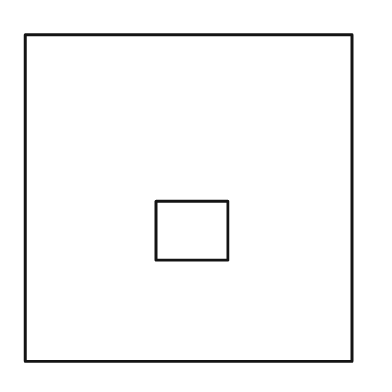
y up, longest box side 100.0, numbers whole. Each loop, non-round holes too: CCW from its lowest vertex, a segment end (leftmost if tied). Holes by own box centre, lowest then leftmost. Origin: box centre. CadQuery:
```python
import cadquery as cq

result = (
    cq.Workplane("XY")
    .moveTo(-50.0, -50.0)
    .lineTo(50.0, -50.0)
    .lineTo(50.0, 50.0)
    .lineTo(-50.0, 50.0)
    .close()
    .moveTo(-10.0, -19.0)
    .lineTo(12.0, -19.0)
    .lineTo(12.0, -1.0)
    .lineTo(-10.0, -1.0)
    .close()
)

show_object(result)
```